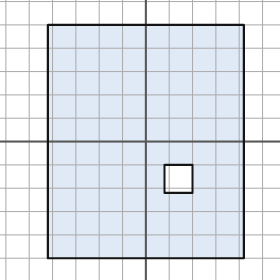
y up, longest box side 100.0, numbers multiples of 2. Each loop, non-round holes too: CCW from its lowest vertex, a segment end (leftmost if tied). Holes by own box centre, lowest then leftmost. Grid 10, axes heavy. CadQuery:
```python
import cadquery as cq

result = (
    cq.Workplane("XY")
    .moveTo(-42.0, -50.0)
    .lineTo(42.0, -50.0)
    .lineTo(42.0, 50.0)
    .lineTo(-42.0, 50.0)
    .close()
    .moveTo(8.0, -22.0)
    .lineTo(20.0, -22.0)
    .lineTo(20.0, -10.0)
    .lineTo(8.0, -10.0)
    .close()
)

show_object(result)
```